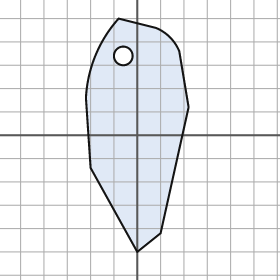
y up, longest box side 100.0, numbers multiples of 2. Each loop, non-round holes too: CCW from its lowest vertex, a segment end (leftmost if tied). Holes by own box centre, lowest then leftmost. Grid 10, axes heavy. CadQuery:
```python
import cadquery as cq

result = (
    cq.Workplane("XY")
    .moveTo(0.0, -50.0)
    .lineTo(10.0, -42.0)
    .lineTo(22.0, 12.0)
    .lineTo(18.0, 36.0)
    .threePointArc((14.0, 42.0), (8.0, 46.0))
    .lineTo(-8.0, 50.0)
    .threePointArc((-18.0, 34.0), (-22.0, 16.0))
    .lineTo(-20.0, -14.0)
    .close()
    .moveTo(-6.0, 34.0)
    .circle(4.0)
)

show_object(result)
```